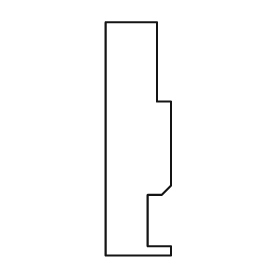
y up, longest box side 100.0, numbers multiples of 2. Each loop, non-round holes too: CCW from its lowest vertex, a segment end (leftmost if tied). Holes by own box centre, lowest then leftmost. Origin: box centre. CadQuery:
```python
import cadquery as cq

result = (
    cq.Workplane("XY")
    .moveTo(-14.0, -50.0)
    .lineTo(14.0, -50.0)
    .lineTo(14.0, -46.0)
    .lineTo(4.0, -46.0)
    .lineTo(4.0, -24.0)
    .lineTo(10.0, -24.0)
    .lineTo(14.0, -20.0)
    .lineTo(14.0, 16.0)
    .lineTo(8.0, 16.0)
    .lineTo(8.0, 50.0)
    .lineTo(-14.0, 50.0)
    .close()
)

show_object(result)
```